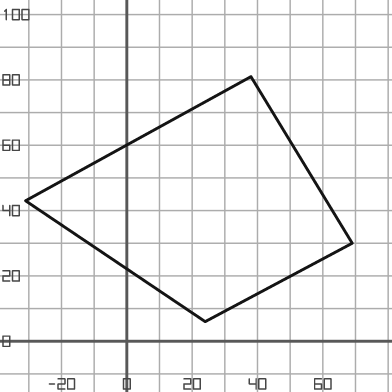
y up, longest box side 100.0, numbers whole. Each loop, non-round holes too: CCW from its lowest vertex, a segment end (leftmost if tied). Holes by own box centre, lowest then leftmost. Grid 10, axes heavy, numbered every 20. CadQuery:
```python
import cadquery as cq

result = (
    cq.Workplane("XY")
    .moveTo(24.0, 6.0)
    .lineTo(69.0, 30.0)
    .lineTo(38.0, 81.0)
    .lineTo(-31.0, 43.0)
    .close()
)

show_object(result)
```